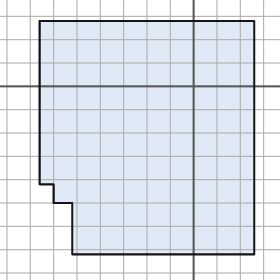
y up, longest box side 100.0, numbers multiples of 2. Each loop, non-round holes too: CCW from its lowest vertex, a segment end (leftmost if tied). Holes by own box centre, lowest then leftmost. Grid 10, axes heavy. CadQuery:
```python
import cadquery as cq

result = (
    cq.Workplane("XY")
    .moveTo(-52.0, -72.0)
    .lineTo(26.0, -72.0)
    .lineTo(26.0, 28.0)
    .lineTo(-66.0, 28.0)
    .lineTo(-66.0, -42.0)
    .lineTo(-60.0, -42.0)
    .lineTo(-60.0, -50.0)
    .lineTo(-52.0, -50.0)
    .close()
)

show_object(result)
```